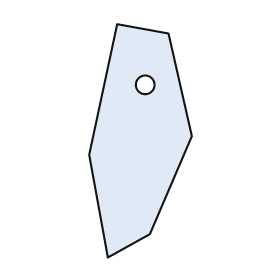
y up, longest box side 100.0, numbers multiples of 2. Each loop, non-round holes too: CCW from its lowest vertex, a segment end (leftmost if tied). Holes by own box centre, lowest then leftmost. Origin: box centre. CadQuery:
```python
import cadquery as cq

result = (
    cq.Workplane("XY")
    .moveTo(-14.0, -50.0)
    .lineTo(4.0, -40.0)
    .lineTo(22.0, 2.0)
    .lineTo(12.0, 46.0)
    .lineTo(-10.0, 50.0)
    .lineTo(-22.0, -6.0)
    .close()
    .moveTo(2.0, 24.0)
    .circle(4.0)
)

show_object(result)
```